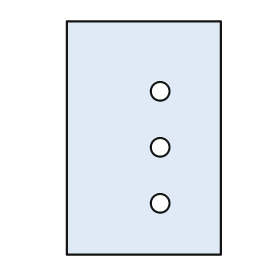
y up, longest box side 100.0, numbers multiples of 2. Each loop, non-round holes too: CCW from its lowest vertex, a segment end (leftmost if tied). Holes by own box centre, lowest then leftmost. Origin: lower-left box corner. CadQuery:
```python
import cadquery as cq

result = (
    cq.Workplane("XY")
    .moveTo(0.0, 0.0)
    .lineTo(66.0, 0.0)
    .lineTo(66.0, 100.0)
    .lineTo(0.0, 100.0)
    .close()
    .moveTo(40.0, 22.0)
    .circle(4.0)
    .moveTo(40.0, 46.0)
    .circle(4.0)
    .moveTo(40.0, 70.0)
    .circle(4.0)
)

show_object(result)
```